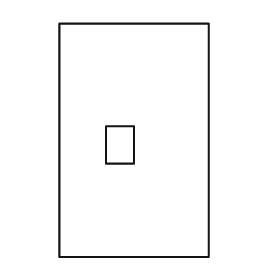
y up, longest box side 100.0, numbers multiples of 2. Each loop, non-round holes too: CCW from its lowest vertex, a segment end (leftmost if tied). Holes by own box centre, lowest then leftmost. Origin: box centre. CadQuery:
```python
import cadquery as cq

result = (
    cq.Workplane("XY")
    .moveTo(-32.0, -50.0)
    .lineTo(32.0, -50.0)
    .lineTo(32.0, 50.0)
    .lineTo(-32.0, 50.0)
    .close()
    .moveTo(-12.0, -10.0)
    .lineTo(0.0, -10.0)
    .lineTo(0.0, 6.0)
    .lineTo(-12.0, 6.0)
    .close()
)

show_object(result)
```